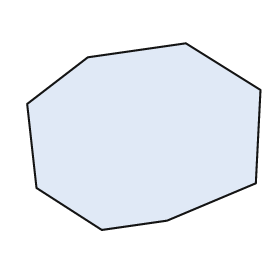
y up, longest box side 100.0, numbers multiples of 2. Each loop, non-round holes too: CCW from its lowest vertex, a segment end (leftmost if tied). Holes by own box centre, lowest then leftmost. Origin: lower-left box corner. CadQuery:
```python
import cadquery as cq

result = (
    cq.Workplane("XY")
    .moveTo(32.0, 0.0)
    .lineTo(60.0, 4.0)
    .lineTo(98.0, 20.0)
    .lineTo(100.0, 60.0)
    .lineTo(68.0, 80.0)
    .lineTo(26.0, 74.0)
    .lineTo(0.0, 54.0)
    .lineTo(4.0, 18.0)
    .close()
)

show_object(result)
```